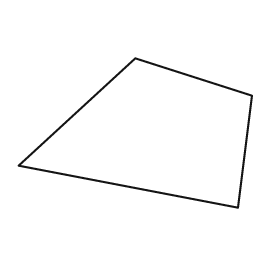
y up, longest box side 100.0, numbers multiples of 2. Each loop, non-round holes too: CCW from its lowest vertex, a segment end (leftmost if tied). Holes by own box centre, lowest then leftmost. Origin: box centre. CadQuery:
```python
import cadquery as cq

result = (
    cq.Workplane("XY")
    .moveTo(44.0, -32.0)
    .lineTo(50.0, 16.0)
    .lineTo(0.0, 32.0)
    .lineTo(-50.0, -14.0)
    .close()
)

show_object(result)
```